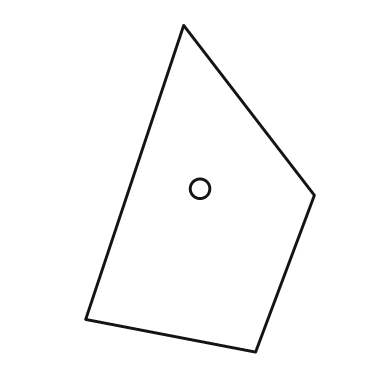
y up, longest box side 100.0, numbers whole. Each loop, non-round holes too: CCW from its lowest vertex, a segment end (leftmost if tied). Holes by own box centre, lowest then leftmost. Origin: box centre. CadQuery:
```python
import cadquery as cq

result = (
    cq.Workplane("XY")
    .moveTo(17.0, -50.0)
    .lineTo(35.0, -2.0)
    .lineTo(-5.0, 50.0)
    .lineTo(-35.0, -40.0)
    .close()
    .moveTo(0.0, 0.0)
    .circle(3.0)
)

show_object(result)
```